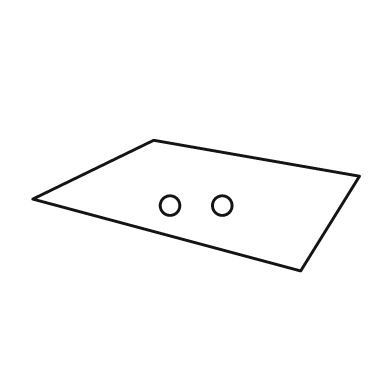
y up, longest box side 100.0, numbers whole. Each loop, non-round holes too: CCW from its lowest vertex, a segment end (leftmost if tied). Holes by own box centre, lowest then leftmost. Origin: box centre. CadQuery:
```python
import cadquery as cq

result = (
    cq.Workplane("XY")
    .moveTo(32.0, -20.0)
    .lineTo(50.0, 9.0)
    .lineTo(-13.0, 20.0)
    .lineTo(-50.0, 2.0)
    .close()
    .moveTo(-8.0, 0.0)
    .circle(3.0)
    .moveTo(8.0, 0.0)
    .circle(3.0)
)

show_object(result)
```